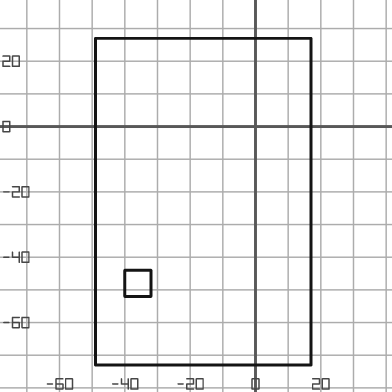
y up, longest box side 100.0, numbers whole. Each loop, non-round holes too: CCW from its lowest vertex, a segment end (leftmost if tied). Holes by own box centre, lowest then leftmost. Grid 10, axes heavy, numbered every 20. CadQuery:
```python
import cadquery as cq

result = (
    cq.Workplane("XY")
    .moveTo(-49.0, -73.0)
    .lineTo(17.0, -73.0)
    .lineTo(17.0, 27.0)
    .lineTo(-49.0, 27.0)
    .close()
    .moveTo(-40.0, -52.0)
    .lineTo(-32.0, -52.0)
    .lineTo(-32.0, -44.0)
    .lineTo(-40.0, -44.0)
    .close()
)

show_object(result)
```